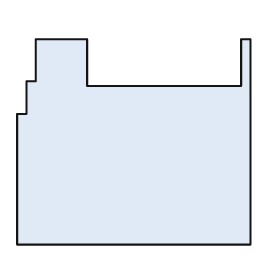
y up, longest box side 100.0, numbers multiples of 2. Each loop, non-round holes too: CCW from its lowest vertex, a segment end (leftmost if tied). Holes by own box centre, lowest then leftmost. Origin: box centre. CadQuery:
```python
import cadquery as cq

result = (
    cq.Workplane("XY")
    .moveTo(-50.0, -44.0)
    .lineTo(50.0, -44.0)
    .lineTo(50.0, 44.0)
    .lineTo(46.0, 44.0)
    .lineTo(46.0, 24.0)
    .lineTo(-20.0, 24.0)
    .lineTo(-20.0, 44.0)
    .lineTo(-42.0, 44.0)
    .lineTo(-42.0, 26.0)
    .lineTo(-46.0, 26.0)
    .lineTo(-46.0, 12.0)
    .lineTo(-50.0, 12.0)
    .close()
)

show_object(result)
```